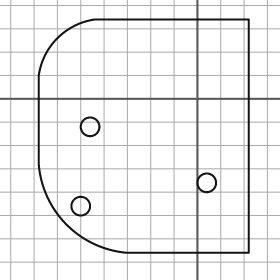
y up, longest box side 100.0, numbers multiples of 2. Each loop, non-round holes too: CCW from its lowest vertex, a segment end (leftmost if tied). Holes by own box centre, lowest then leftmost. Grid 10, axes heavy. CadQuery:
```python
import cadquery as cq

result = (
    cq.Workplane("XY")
    .moveTo(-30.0, -66.0)
    .lineTo(22.0, -66.0)
    .lineTo(22.0, 34.0)
    .lineTo(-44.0, 34.0)
    .threePointArc((-60.0, 26.0), (-68.0, 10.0))
    .lineTo(-68.0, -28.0)
    .threePointArc((-56.0, -54.0), (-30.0, -66.0))
    .close()
    .moveTo(-50.0, -46.0)
    .circle(4.0)
    .moveTo(4.0, -36.0)
    .circle(4.0)
    .moveTo(-46.0, -12.0)
    .circle(4.0)
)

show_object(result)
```